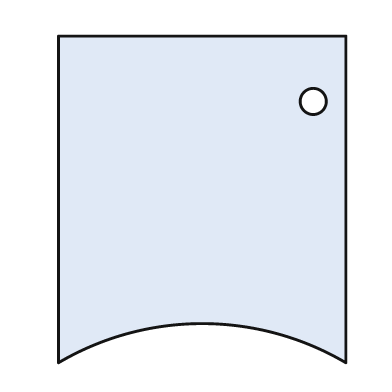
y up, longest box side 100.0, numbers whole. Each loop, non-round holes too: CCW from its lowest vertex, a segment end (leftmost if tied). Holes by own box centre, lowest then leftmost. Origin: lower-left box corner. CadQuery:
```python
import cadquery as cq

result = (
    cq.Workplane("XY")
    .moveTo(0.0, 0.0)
    .threePointArc((44.0, 12.0), (88.0, 0.0))
    .lineTo(88.0, 100.0)
    .lineTo(0.0, 100.0)
    .close()
    .moveTo(78.0, 80.0)
    .circle(4.0)
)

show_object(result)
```